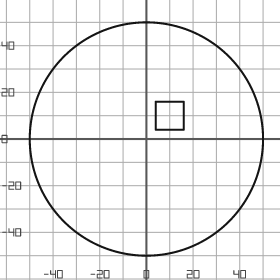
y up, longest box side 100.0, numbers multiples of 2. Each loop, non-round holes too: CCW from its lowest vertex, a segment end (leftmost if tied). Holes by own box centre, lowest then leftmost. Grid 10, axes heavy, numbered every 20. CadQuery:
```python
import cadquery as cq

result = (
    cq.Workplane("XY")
    .moveTo(0.0, 0.0)
    .circle(50.0)
    .moveTo(4.0, 4.0)
    .lineTo(16.0, 4.0)
    .lineTo(16.0, 16.0)
    .lineTo(4.0, 16.0)
    .close()
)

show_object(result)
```